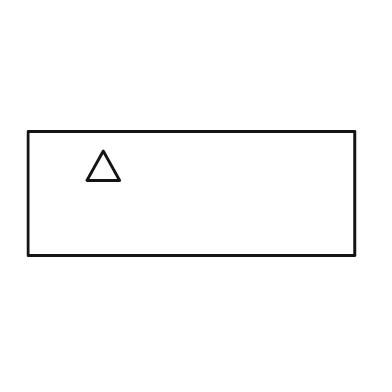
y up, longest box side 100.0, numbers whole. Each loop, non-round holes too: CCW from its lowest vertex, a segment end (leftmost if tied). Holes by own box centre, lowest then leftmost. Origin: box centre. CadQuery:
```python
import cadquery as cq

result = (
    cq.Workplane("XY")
    .moveTo(-50.0, -19.0)
    .lineTo(50.0, -19.0)
    .lineTo(50.0, 19.0)
    .lineTo(-50.0, 19.0)
    .close()
    .moveTo(-32.0, 4.0)
    .lineTo(-22.0, 4.0)
    .lineTo(-27.0, 13.0)
    .close()
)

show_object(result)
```